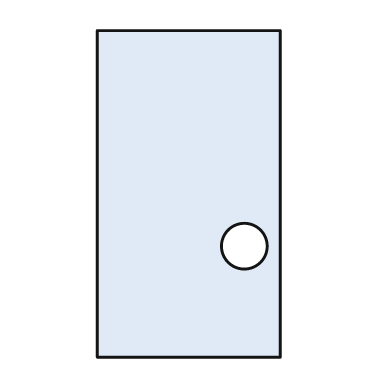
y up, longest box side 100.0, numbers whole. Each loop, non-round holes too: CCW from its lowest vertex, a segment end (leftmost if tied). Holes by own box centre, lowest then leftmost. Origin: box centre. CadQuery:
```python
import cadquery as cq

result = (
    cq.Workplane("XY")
    .moveTo(-28.0, -50.0)
    .lineTo(28.0, -50.0)
    .lineTo(28.0, 50.0)
    .lineTo(-28.0, 50.0)
    .close()
    .moveTo(17.0, -16.0)
    .circle(7.0)
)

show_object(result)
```